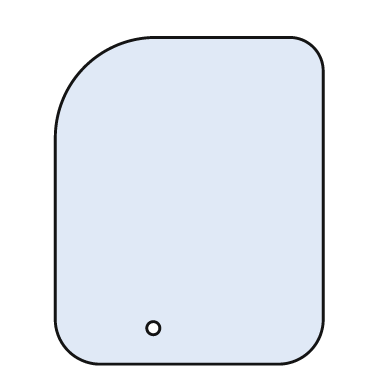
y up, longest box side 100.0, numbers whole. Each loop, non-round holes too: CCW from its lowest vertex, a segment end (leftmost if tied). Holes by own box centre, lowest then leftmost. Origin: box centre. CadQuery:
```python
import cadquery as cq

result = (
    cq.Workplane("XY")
    .moveTo(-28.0, -50.0)
    .lineTo(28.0, -50.0)
    .threePointArc((37.0, -46.0), (41.0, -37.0))
    .lineTo(41.0, 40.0)
    .threePointArc((38.0, 47.0), (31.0, 50.0))
    .lineTo(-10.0, 50.0)
    .threePointArc((-32.0, 41.0), (-41.0, 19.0))
    .lineTo(-41.0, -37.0)
    .threePointArc((-37.0, -46.0), (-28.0, -50.0))
    .close()
    .moveTo(-11.0, -39.0)
    .circle(2.0)
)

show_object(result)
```